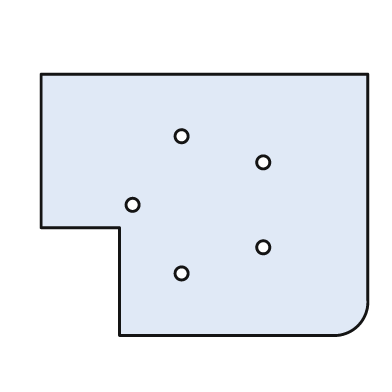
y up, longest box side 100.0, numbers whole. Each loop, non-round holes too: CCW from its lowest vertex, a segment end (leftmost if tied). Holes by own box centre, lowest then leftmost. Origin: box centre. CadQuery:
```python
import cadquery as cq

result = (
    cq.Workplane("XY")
    .moveTo(-26.0, -40.0)
    .lineTo(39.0, -40.0)
    .threePointArc((47.0, -37.0), (50.0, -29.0))
    .lineTo(50.0, 40.0)
    .lineTo(-50.0, 40.0)
    .lineTo(-50.0, -7.0)
    .lineTo(-26.0, -7.0)
    .close()
    .moveTo(-7.0, -21.0)
    .circle(2.0)
    .moveTo(18.0, -13.0)
    .circle(2.0)
    .moveTo(-22.0, 0.0)
    .circle(2.0)
    .moveTo(18.0, 13.0)
    .circle(2.0)
    .moveTo(-7.0, 21.0)
    .circle(2.0)
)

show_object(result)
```